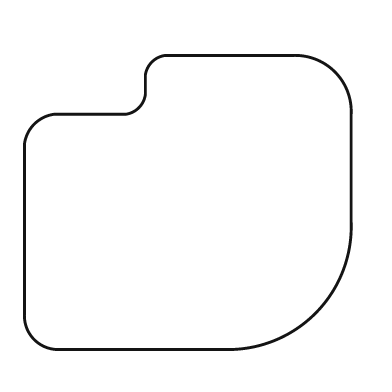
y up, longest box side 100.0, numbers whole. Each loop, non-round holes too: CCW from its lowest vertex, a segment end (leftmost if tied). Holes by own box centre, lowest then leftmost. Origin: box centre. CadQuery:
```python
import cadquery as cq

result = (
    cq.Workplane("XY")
    .moveTo(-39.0, -45.0)
    .lineTo(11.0, -45.0)
    .threePointArc((39.0, -34.0), (50.0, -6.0))
    .lineTo(50.0, 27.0)
    .threePointArc((45.0, 40.0), (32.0, 45.0))
    .lineTo(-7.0, 45.0)
    .threePointArc((-11.0, 43.0), (-13.0, 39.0))
    .lineTo(-13.0, 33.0)
    .threePointArc((-15.0, 29.0), (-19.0, 27.0))
    .lineTo(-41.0, 27.0)
    .threePointArc((-47.0, 24.0), (-50.0, 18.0))
    .lineTo(-50.0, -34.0)
    .threePointArc((-47.0, -42.0), (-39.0, -45.0))
    .close()
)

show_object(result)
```